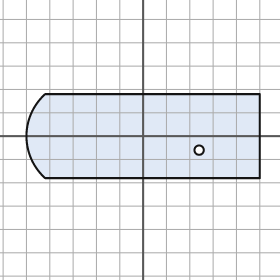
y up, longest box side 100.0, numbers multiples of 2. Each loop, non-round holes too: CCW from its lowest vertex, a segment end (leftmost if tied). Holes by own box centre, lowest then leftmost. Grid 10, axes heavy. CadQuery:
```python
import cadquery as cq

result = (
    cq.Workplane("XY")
    .moveTo(-42.0, -18.0)
    .lineTo(50.0, -18.0)
    .lineTo(50.0, 18.0)
    .lineTo(-42.0, 18.0)
    .threePointArc((-50.0, 0.0), (-42.0, -18.0))
    .close()
    .moveTo(24.0, -6.0)
    .circle(2.0)
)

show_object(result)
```